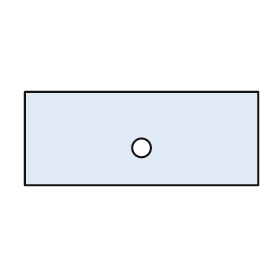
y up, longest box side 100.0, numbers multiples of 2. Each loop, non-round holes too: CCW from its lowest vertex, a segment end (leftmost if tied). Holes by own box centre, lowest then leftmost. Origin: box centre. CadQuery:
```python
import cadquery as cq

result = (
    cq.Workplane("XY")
    .moveTo(-50.0, -20.0)
    .lineTo(50.0, -20.0)
    .lineTo(50.0, 20.0)
    .lineTo(-50.0, 20.0)
    .close()
    .moveTo(0.0, -4.0)
    .circle(4.0)
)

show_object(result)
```